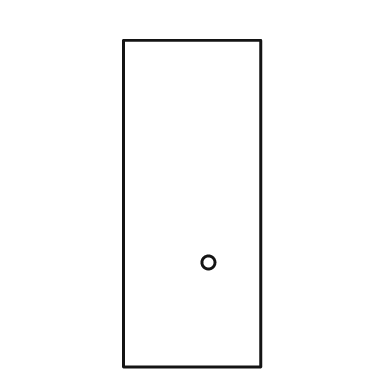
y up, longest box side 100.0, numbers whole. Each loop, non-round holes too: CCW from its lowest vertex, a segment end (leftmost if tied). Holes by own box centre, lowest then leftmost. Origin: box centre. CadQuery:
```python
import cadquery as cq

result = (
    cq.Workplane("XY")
    .moveTo(-21.0, -50.0)
    .lineTo(21.0, -50.0)
    .lineTo(21.0, 50.0)
    .lineTo(-21.0, 50.0)
    .close()
    .moveTo(5.0, -18.0)
    .circle(2.0)
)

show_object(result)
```